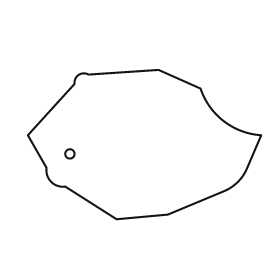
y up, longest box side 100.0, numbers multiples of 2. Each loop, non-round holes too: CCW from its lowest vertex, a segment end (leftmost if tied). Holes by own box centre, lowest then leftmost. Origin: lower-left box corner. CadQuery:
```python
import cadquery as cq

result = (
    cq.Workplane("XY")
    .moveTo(38.0, 0.0)
    .lineTo(60.0, 2.0)
    .lineTo(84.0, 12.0)
    .threePointArc((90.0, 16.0), (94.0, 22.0))
    .lineTo(100.0, 36.0)
    .threePointArc((84.0, 42.0), (74.0, 56.0))
    .lineTo(56.0, 64.0)
    .lineTo(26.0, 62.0)
    .threePointArc((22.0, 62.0), (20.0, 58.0))
    .lineTo(0.0, 36.0)
    .lineTo(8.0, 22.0)
    .threePointArc((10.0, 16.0), (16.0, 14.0))
    .close()
    .moveTo(18.0, 28.0)
    .circle(2.0)
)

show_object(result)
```